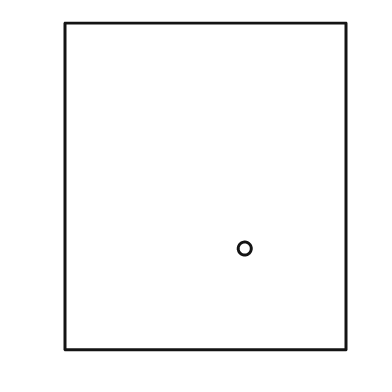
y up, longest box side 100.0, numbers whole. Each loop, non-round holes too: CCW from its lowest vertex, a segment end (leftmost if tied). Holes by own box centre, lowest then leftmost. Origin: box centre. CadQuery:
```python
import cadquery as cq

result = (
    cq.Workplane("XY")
    .moveTo(-43.0, -50.0)
    .lineTo(43.0, -50.0)
    .lineTo(43.0, 50.0)
    .lineTo(-43.0, 50.0)
    .close()
    .moveTo(12.0, -19.0)
    .circle(2.0)
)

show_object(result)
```